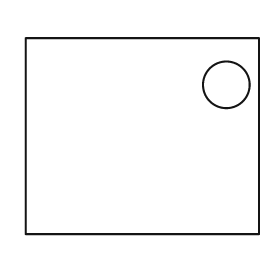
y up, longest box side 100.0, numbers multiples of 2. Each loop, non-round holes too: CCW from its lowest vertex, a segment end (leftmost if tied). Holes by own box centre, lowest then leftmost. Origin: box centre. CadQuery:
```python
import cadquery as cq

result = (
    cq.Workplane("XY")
    .moveTo(-50.0, -42.0)
    .lineTo(50.0, -42.0)
    .lineTo(50.0, 42.0)
    .lineTo(-50.0, 42.0)
    .close()
    .moveTo(36.0, 22.0)
    .circle(10.0)
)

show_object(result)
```